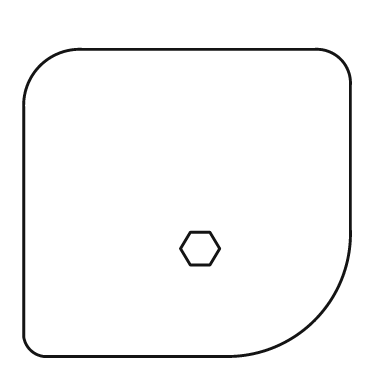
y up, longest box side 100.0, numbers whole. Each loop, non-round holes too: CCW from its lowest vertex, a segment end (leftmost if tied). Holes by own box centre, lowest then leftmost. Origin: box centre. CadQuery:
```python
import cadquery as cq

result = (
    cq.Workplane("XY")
    .moveTo(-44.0, -47.0)
    .lineTo(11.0, -47.0)
    .threePointArc((39.0, -36.0), (50.0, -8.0))
    .lineTo(50.0, 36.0)
    .threePointArc((47.0, 44.0), (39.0, 47.0))
    .lineTo(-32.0, 47.0)
    .threePointArc((-45.0, 42.0), (-50.0, 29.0))
    .lineTo(-50.0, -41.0)
    .threePointArc((-48.0, -45.0), (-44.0, -47.0))
    .close()
    .moveTo(1.0, -19.0)
    .lineTo(7.0, -19.0)
    .lineTo(10.0, -14.0)
    .lineTo(7.0, -9.0)
    .lineTo(1.0, -9.0)
    .lineTo(-2.0, -14.0)
    .close()
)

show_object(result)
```